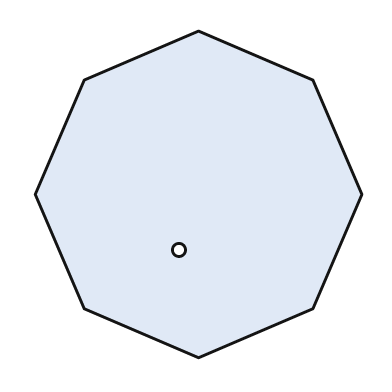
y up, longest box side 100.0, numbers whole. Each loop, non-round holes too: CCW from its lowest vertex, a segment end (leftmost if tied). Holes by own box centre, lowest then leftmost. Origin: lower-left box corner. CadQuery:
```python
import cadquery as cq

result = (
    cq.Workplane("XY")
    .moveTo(50.0, 0.0)
    .lineTo(85.0, 15.0)
    .lineTo(100.0, 50.0)
    .lineTo(85.0, 85.0)
    .lineTo(50.0, 100.0)
    .lineTo(15.0, 85.0)
    .lineTo(0.0, 50.0)
    .lineTo(15.0, 15.0)
    .close()
    .moveTo(44.0, 33.0)
    .circle(2.0)
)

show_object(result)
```